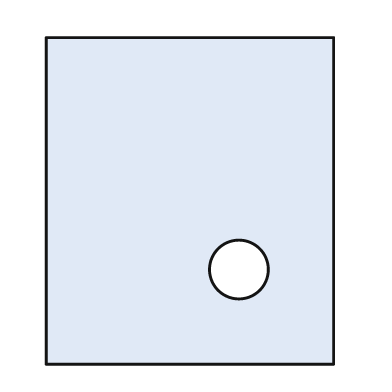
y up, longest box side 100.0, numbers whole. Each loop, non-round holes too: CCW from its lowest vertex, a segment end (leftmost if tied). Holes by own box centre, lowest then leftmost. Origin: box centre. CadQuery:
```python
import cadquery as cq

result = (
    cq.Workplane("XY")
    .moveTo(-44.0, -50.0)
    .lineTo(44.0, -50.0)
    .lineTo(44.0, 50.0)
    .lineTo(-44.0, 50.0)
    .close()
    .moveTo(15.0, -21.0)
    .circle(9.0)
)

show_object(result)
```